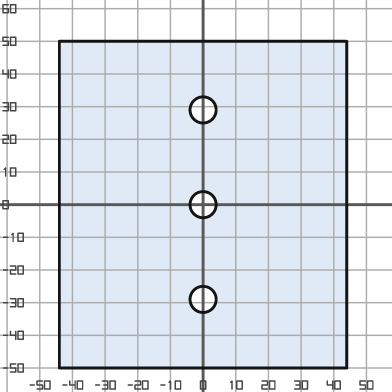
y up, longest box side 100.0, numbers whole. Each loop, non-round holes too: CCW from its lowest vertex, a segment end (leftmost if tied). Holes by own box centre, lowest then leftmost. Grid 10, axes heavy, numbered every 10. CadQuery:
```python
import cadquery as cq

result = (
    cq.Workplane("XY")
    .moveTo(-44.0, -50.0)
    .lineTo(44.0, -50.0)
    .lineTo(44.0, 50.0)
    .lineTo(-44.0, 50.0)
    .close()
    .moveTo(0.0, -29.0)
    .circle(4.0)
    .moveTo(0.0, 0.0)
    .circle(4.0)
    .moveTo(0.0, 29.0)
    .circle(4.0)
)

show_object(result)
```